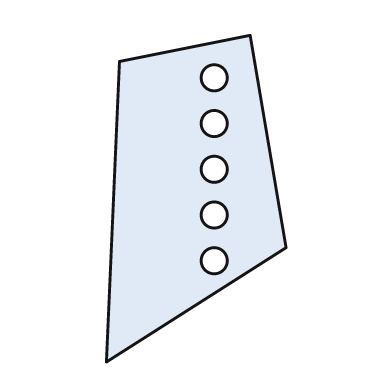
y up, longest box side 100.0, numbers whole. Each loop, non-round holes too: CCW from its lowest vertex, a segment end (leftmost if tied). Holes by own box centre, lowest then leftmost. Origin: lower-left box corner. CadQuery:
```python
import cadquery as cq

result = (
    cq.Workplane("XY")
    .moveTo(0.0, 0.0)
    .lineTo(55.0, 35.0)
    .lineTo(44.0, 100.0)
    .lineTo(4.0, 92.0)
    .close()
    .moveTo(33.0, 31.0)
    .circle(4.0)
    .moveTo(33.0, 45.0)
    .circle(4.0)
    .moveTo(33.0, 59.0)
    .circle(4.0)
    .moveTo(33.0, 73.0)
    .circle(4.0)
    .moveTo(33.0, 87.0)
    .circle(4.0)
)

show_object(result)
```